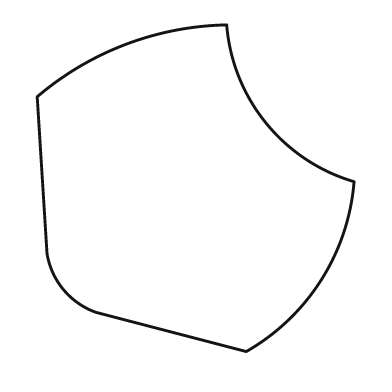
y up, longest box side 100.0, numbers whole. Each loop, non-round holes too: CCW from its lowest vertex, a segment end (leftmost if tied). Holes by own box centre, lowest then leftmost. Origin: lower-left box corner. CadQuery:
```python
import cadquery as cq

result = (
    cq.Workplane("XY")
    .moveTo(64.0, 0.0)
    .threePointArc((87.0, 22.0), (97.0, 52.0))
    .threePointArc((70.0, 70.0), (58.0, 100.0))
    .threePointArc((27.0, 94.0), (0.0, 78.0))
    .lineTo(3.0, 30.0)
    .threePointArc((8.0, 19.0), (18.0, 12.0))
    .close()
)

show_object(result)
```